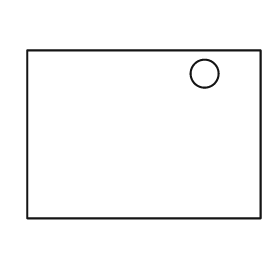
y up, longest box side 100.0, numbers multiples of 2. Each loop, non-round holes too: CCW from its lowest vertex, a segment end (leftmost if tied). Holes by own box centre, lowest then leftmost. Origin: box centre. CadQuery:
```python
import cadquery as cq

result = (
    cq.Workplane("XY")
    .moveTo(-50.0, -36.0)
    .lineTo(50.0, -36.0)
    .lineTo(50.0, 36.0)
    .lineTo(-50.0, 36.0)
    .close()
    .moveTo(26.0, 26.0)
    .circle(6.0)
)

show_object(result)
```